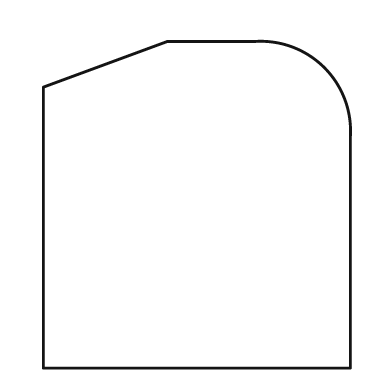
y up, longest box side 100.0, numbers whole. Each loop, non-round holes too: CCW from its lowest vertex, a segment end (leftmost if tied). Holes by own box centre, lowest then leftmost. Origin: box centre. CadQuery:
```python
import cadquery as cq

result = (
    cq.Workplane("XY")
    .moveTo(-47.0, -50.0)
    .lineTo(47.0, -50.0)
    .lineTo(47.0, 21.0)
    .threePointArc((39.0, 42.0), (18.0, 50.0))
    .lineTo(-9.0, 50.0)
    .lineTo(-47.0, 36.0)
    .close()
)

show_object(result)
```